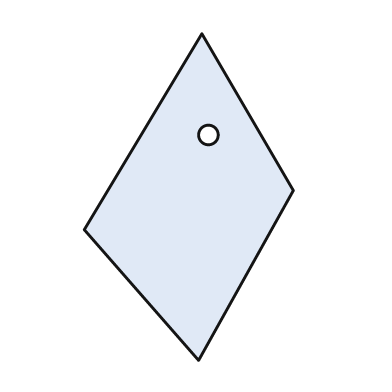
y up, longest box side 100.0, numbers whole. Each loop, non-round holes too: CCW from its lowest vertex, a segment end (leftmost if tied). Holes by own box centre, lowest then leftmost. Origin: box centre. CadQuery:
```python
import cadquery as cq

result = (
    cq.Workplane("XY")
    .moveTo(3.0, -50.0)
    .lineTo(32.0, 2.0)
    .lineTo(4.0, 50.0)
    .lineTo(-32.0, -10.0)
    .close()
    .moveTo(6.0, 19.0)
    .circle(3.0)
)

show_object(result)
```